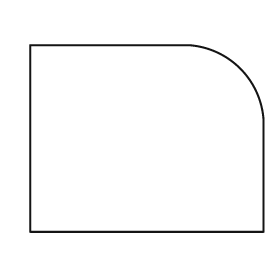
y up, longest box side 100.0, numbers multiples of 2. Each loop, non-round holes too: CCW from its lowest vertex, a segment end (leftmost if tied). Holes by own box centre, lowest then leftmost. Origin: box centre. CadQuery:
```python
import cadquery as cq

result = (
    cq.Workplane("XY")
    .moveTo(-50.0, -40.0)
    .lineTo(50.0, -40.0)
    .lineTo(50.0, 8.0)
    .threePointArc((40.0, 30.0), (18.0, 40.0))
    .lineTo(-50.0, 40.0)
    .close()
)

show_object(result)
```